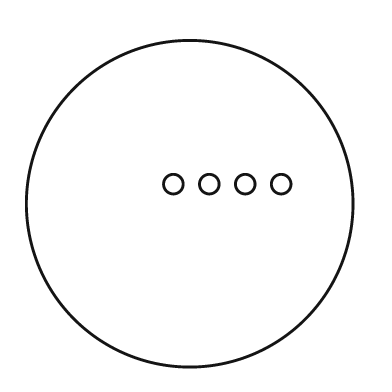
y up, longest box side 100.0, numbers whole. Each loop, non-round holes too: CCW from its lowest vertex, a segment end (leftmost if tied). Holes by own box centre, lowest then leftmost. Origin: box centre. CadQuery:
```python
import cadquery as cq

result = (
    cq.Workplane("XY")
    .moveTo(0.0, 0.0)
    .circle(50.0)
    .moveTo(-5.0, 6.0)
    .circle(3.0)
    .moveTo(6.0, 6.0)
    .circle(3.0)
    .moveTo(17.0, 6.0)
    .circle(3.0)
    .moveTo(28.0, 6.0)
    .circle(3.0)
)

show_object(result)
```